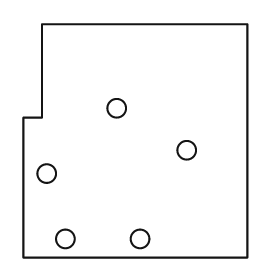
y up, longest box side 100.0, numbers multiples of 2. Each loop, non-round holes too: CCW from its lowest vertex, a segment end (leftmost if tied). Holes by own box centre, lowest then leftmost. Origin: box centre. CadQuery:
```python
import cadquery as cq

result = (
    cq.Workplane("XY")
    .moveTo(-48.0, -50.0)
    .lineTo(48.0, -50.0)
    .lineTo(48.0, 50.0)
    .lineTo(-40.0, 50.0)
    .lineTo(-40.0, 10.0)
    .lineTo(-48.0, 10.0)
    .close()
    .moveTo(-30.0, -42.0)
    .circle(4.0)
    .moveTo(2.0, -42.0)
    .circle(4.0)
    .moveTo(-38.0, -14.0)
    .circle(4.0)
    .moveTo(22.0, -4.0)
    .circle(4.0)
    .moveTo(-8.0, 14.0)
    .circle(4.0)
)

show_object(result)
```